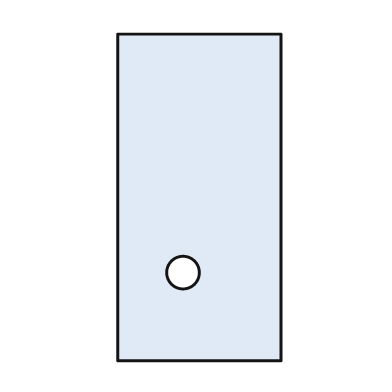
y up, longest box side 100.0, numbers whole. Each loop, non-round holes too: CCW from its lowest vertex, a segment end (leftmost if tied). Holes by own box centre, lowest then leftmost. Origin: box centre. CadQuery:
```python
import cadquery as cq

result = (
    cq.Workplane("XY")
    .moveTo(-25.0, -50.0)
    .lineTo(25.0, -50.0)
    .lineTo(25.0, 50.0)
    .lineTo(-25.0, 50.0)
    .close()
    .moveTo(-5.0, -23.0)
    .circle(5.0)
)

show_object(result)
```